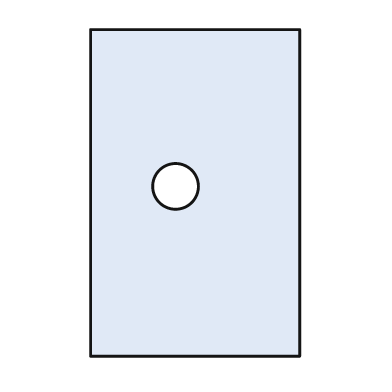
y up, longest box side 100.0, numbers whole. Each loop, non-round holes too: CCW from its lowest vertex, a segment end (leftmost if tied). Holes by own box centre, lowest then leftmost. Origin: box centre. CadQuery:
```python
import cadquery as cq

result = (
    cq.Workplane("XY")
    .moveTo(-32.0, -50.0)
    .lineTo(32.0, -50.0)
    .lineTo(32.0, 50.0)
    .lineTo(-32.0, 50.0)
    .close()
    .moveTo(-6.0, 2.0)
    .circle(7.0)
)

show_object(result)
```